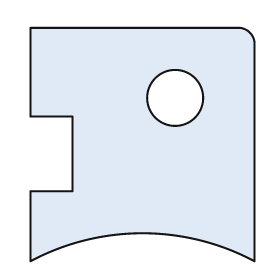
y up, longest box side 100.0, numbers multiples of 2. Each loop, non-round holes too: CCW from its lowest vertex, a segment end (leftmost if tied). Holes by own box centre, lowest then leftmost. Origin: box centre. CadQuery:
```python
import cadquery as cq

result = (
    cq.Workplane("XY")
    .moveTo(-48.0, -50.0)
    .threePointArc((0.0, -38.0), (48.0, -50.0))
    .lineTo(48.0, 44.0)
    .threePointArc((46.0, 48.0), (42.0, 50.0))
    .lineTo(-48.0, 50.0)
    .lineTo(-48.0, 12.0)
    .lineTo(-30.0, 12.0)
    .lineTo(-30.0, -20.0)
    .lineTo(-48.0, -20.0)
    .close()
    .moveTo(14.0, 20.0)
    .circle(12.0)
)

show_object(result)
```